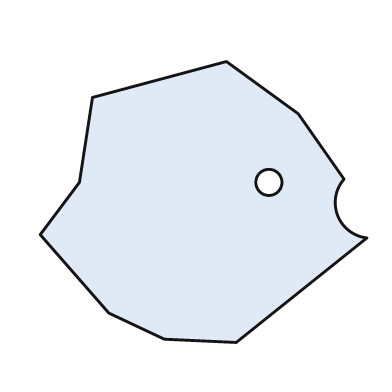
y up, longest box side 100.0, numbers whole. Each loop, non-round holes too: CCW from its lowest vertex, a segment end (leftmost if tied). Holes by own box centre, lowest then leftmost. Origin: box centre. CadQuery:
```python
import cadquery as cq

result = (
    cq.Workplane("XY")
    .moveTo(10.0, -43.0)
    .lineTo(50.0, -11.0)
    .threePointArc((41.0, -4.0), (43.0, 7.0))
    .lineTo(29.0, 27.0)
    .lineTo(7.0, 43.0)
    .lineTo(-34.0, 32.0)
    .lineTo(-38.0, 6.0)
    .lineTo(-50.0, -10.0)
    .lineTo(-29.0, -34.0)
    .lineTo(-12.0, -42.0)
    .close()
    .moveTo(20.0, 6.0)
    .circle(4.0)
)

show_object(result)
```